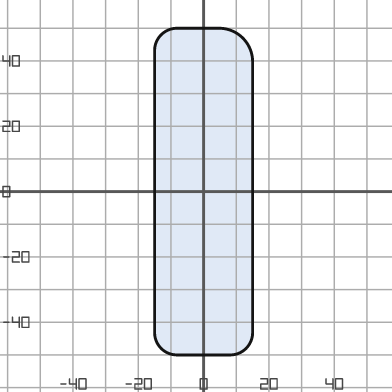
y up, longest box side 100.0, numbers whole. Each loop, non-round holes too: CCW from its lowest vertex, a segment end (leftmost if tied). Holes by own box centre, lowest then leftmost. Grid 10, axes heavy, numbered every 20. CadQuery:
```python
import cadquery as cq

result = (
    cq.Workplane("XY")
    .moveTo(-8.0, -50.0)
    .lineTo(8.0, -50.0)
    .threePointArc((13.0, -48.0), (15.0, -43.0))
    .lineTo(15.0, 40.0)
    .threePointArc((12.0, 47.0), (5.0, 50.0))
    .lineTo(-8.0, 50.0)
    .threePointArc((-13.0, 48.0), (-15.0, 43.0))
    .lineTo(-15.0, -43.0)
    .threePointArc((-13.0, -48.0), (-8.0, -50.0))
    .close()
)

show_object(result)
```